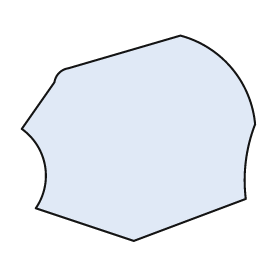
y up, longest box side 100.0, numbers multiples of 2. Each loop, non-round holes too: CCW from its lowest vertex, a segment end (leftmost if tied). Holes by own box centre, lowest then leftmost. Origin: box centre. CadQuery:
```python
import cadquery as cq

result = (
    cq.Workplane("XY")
    .moveTo(-2.0, -44.0)
    .lineTo(46.0, -26.0)
    .threePointArc((46.0, -10.0), (50.0, 6.0))
    .threePointArc((40.0, 30.0), (18.0, 44.0))
    .lineTo(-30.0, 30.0)
    .threePointArc((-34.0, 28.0), (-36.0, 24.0))
    .lineTo(-50.0, 4.0)
    .threePointArc((-40.0, -12.0), (-44.0, -30.0))
    .close()
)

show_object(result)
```